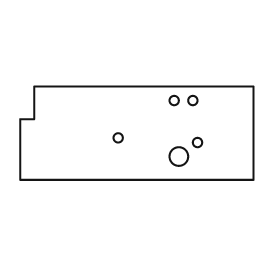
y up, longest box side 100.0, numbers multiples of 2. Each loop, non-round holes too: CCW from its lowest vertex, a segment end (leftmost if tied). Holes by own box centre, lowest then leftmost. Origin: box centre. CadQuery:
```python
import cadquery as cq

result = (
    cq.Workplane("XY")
    .moveTo(-50.0, -20.0)
    .lineTo(50.0, -20.0)
    .lineTo(50.0, 20.0)
    .lineTo(-44.0, 20.0)
    .lineTo(-44.0, 6.0)
    .lineTo(-50.0, 6.0)
    .close()
    .moveTo(18.0, -10.0)
    .circle(4.0)
    .moveTo(26.0, -4.0)
    .circle(2.0)
    .moveTo(-8.0, -2.0)
    .circle(2.0)
    .moveTo(16.0, 14.0)
    .circle(2.0)
    .moveTo(24.0, 14.0)
    .circle(2.0)
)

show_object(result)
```